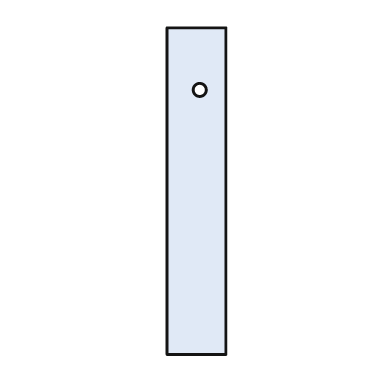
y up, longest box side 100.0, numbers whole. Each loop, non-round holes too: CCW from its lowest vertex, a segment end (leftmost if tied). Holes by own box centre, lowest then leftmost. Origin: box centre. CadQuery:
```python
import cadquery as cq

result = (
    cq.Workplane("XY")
    .moveTo(-9.0, -50.0)
    .lineTo(9.0, -50.0)
    .lineTo(9.0, 50.0)
    .lineTo(-9.0, 50.0)
    .close()
    .moveTo(1.0, 31.0)
    .circle(2.0)
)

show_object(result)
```